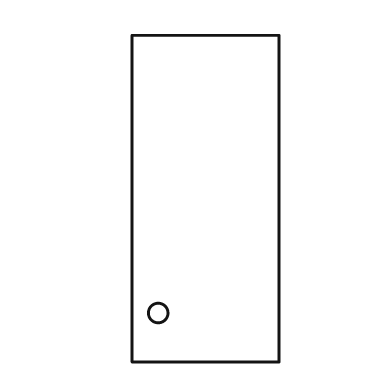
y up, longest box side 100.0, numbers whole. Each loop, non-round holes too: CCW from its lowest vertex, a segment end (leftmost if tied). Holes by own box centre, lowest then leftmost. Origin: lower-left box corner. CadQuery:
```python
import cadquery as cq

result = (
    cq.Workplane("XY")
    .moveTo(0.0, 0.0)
    .lineTo(45.0, 0.0)
    .lineTo(45.0, 100.0)
    .lineTo(0.0, 100.0)
    .close()
    .moveTo(8.0, 15.0)
    .circle(3.0)
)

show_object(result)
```